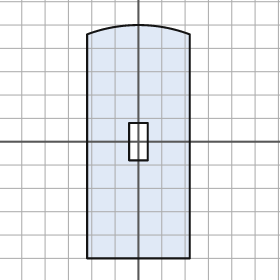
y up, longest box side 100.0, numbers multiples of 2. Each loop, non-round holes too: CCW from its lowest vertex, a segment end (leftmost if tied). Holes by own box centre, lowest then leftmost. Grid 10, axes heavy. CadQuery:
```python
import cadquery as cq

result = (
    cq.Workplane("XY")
    .moveTo(-22.0, -50.0)
    .lineTo(22.0, -50.0)
    .lineTo(22.0, 46.0)
    .threePointArc((0.0, 50.0), (-22.0, 46.0))
    .close()
    .moveTo(-4.0, -8.0)
    .lineTo(4.0, -8.0)
    .lineTo(4.0, 8.0)
    .lineTo(-4.0, 8.0)
    .close()
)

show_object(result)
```